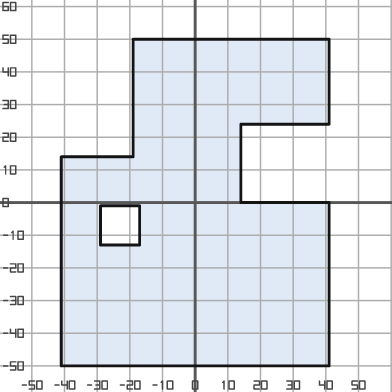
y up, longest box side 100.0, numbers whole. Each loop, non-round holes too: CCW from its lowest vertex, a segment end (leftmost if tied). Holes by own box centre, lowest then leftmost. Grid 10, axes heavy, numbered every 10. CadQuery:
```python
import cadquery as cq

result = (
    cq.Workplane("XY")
    .moveTo(-41.0, -50.0)
    .lineTo(41.0, -50.0)
    .lineTo(41.0, 0.0)
    .lineTo(14.0, 0.0)
    .lineTo(14.0, 24.0)
    .lineTo(41.0, 24.0)
    .lineTo(41.0, 50.0)
    .lineTo(-19.0, 50.0)
    .lineTo(-19.0, 14.0)
    .lineTo(-41.0, 14.0)
    .close()
    .moveTo(-29.0, -13.0)
    .lineTo(-17.0, -13.0)
    .lineTo(-17.0, -1.0)
    .lineTo(-29.0, -1.0)
    .close()
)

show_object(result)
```